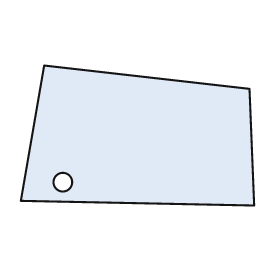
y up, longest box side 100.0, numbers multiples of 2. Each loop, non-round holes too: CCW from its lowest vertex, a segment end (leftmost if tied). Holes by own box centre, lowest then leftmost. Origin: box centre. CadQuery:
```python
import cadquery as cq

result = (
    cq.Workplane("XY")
    .moveTo(50.0, -30.0)
    .lineTo(48.0, 20.0)
    .lineTo(-40.0, 30.0)
    .lineTo(-50.0, -28.0)
    .close()
    .moveTo(-32.0, -20.0)
    .circle(4.0)
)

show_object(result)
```